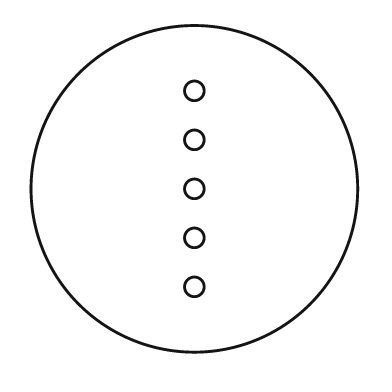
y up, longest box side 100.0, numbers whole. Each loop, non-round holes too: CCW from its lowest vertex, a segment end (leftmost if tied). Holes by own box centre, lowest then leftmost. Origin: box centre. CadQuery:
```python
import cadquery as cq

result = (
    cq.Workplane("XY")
    .moveTo(0.0, 0.0)
    .circle(50.0)
    .moveTo(0.0, -30.0)
    .circle(3.0)
    .moveTo(0.0, -15.0)
    .circle(3.0)
    .moveTo(0.0, 0.0)
    .circle(3.0)
    .moveTo(0.0, 15.0)
    .circle(3.0)
    .moveTo(0.0, 30.0)
    .circle(3.0)
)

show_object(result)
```